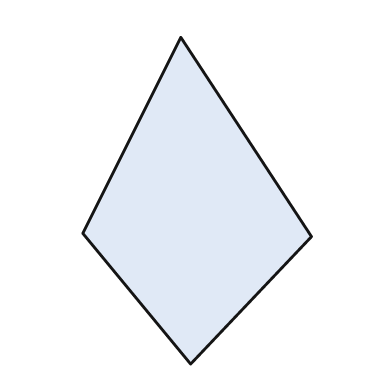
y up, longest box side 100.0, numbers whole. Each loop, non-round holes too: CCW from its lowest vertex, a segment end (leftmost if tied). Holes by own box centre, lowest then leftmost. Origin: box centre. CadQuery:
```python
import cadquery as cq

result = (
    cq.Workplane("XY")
    .moveTo(-2.0, -50.0)
    .lineTo(35.0, -11.0)
    .lineTo(-5.0, 50.0)
    .lineTo(-35.0, -10.0)
    .close()
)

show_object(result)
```